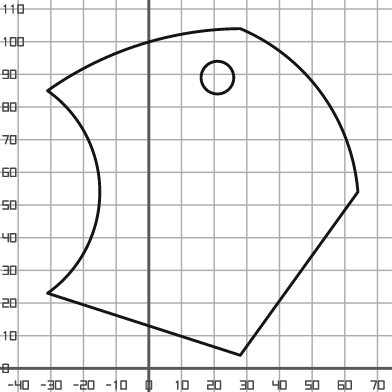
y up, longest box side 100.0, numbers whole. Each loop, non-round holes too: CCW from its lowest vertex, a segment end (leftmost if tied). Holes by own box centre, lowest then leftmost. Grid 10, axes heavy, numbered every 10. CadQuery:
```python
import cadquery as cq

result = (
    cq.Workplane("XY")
    .moveTo(28.0, 4.0)
    .lineTo(64.0, 54.0)
    .threePointArc((53.0, 84.0), (28.0, 104.0))
    .threePointArc((-3.0, 99.0), (-31.0, 85.0))
    .threePointArc((-15.0, 54.0), (-31.0, 23.0))
    .close()
    .moveTo(21.0, 89.0)
    .circle(5.0)
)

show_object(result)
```